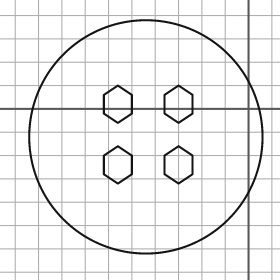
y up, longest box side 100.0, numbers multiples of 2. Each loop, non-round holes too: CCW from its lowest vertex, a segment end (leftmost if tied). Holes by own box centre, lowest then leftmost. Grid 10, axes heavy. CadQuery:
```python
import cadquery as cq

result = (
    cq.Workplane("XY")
    .moveTo(-44.0, -12.0)
    .circle(50.0)
    .moveTo(-56.0, -32.0)
    .lineTo(-50.0, -28.0)
    .lineTo(-50.0, -20.0)
    .lineTo(-56.0, -16.0)
    .lineTo(-62.0, -20.0)
    .lineTo(-62.0, -28.0)
    .close()
    .moveTo(-30.0, -32.0)
    .lineTo(-24.0, -28.0)
    .lineTo(-24.0, -20.0)
    .lineTo(-30.0, -16.0)
    .lineTo(-36.0, -20.0)
    .lineTo(-36.0, -28.0)
    .close()
    .moveTo(-56.0, -6.0)
    .lineTo(-50.0, -2.0)
    .lineTo(-50.0, 6.0)
    .lineTo(-56.0, 10.0)
    .lineTo(-62.0, 6.0)
    .lineTo(-62.0, -2.0)
    .close()
    .moveTo(-30.0, -6.0)
    .lineTo(-24.0, -2.0)
    .lineTo(-24.0, 6.0)
    .lineTo(-30.0, 10.0)
    .lineTo(-36.0, 6.0)
    .lineTo(-36.0, -2.0)
    .close()
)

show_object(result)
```